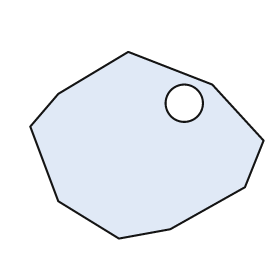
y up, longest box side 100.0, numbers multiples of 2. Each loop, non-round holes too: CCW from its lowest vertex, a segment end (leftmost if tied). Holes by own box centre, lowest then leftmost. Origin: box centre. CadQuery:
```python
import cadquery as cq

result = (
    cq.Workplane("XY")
    .moveTo(-12.0, -40.0)
    .lineTo(10.0, -36.0)
    .lineTo(42.0, -18.0)
    .lineTo(50.0, 2.0)
    .lineTo(28.0, 26.0)
    .lineTo(-8.0, 40.0)
    .lineTo(-38.0, 22.0)
    .lineTo(-50.0, 8.0)
    .lineTo(-38.0, -24.0)
    .close()
    .moveTo(16.0, 18.0)
    .circle(8.0)
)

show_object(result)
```